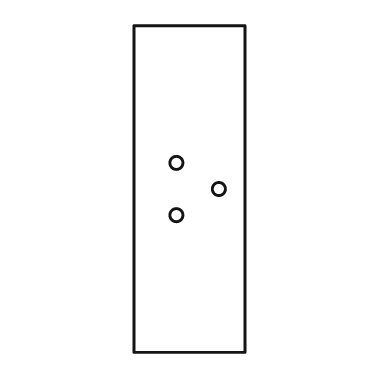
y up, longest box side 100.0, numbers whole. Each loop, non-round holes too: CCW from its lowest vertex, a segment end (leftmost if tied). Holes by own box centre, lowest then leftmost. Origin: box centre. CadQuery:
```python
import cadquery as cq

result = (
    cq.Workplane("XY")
    .moveTo(-17.0, -50.0)
    .lineTo(17.0, -50.0)
    .lineTo(17.0, 50.0)
    .lineTo(-17.0, 50.0)
    .close()
    .moveTo(-4.0, -8.0)
    .circle(2.0)
    .moveTo(9.0, 0.0)
    .circle(2.0)
    .moveTo(-4.0, 8.0)
    .circle(2.0)
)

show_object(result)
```